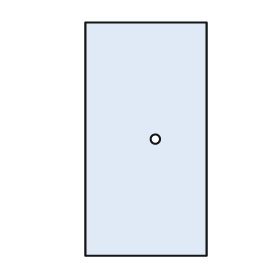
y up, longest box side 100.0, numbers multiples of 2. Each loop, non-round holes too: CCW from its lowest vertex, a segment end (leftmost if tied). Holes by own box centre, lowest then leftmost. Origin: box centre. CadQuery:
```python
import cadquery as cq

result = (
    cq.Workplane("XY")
    .moveTo(-26.0, -50.0)
    .lineTo(26.0, -50.0)
    .lineTo(26.0, 50.0)
    .lineTo(-26.0, 50.0)
    .close()
    .moveTo(4.0, 0.0)
    .circle(2.0)
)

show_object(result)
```